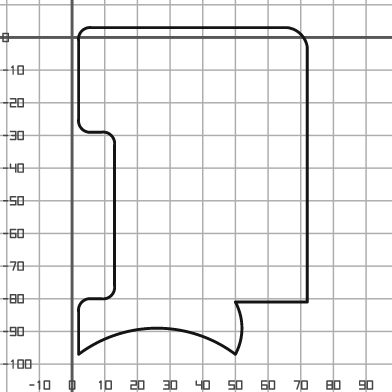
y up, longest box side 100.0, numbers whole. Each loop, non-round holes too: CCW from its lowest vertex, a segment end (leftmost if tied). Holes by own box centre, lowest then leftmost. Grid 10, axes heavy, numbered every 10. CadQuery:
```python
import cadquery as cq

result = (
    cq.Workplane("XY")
    .moveTo(2.0, -97.0)
    .threePointArc((26.0, -89.0), (50.0, -97.0))
    .threePointArc((52.0, -89.0), (50.0, -81.0))
    .lineTo(72.0, -81.0)
    .lineTo(72.0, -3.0)
    .threePointArc((70.0, 1.0), (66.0, 3.0))
    .lineTo(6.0, 3.0)
    .threePointArc((3.0, 2.0), (2.0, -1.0))
    .lineTo(2.0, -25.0)
    .threePointArc((3.0, -28.0), (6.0, -29.0))
    .lineTo(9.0, -29.0)
    .threePointArc((12.0, -30.0), (13.0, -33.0))
    .lineTo(13.0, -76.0)
    .threePointArc((12.0, -79.0), (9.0, -80.0))
    .lineTo(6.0, -80.0)
    .threePointArc((3.0, -81.0), (2.0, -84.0))
    .close()
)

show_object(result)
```